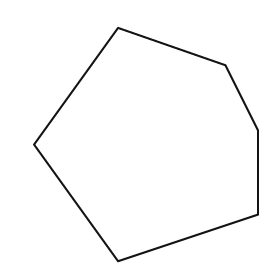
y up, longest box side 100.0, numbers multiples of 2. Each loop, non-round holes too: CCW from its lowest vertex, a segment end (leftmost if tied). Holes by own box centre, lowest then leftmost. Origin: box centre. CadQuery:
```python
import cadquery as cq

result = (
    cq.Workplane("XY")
    .moveTo(-12.0, -50.0)
    .lineTo(48.0, -30.0)
    .lineTo(48.0, 6.0)
    .lineTo(34.0, 34.0)
    .lineTo(-12.0, 50.0)
    .lineTo(-48.0, 0.0)
    .close()
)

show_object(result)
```